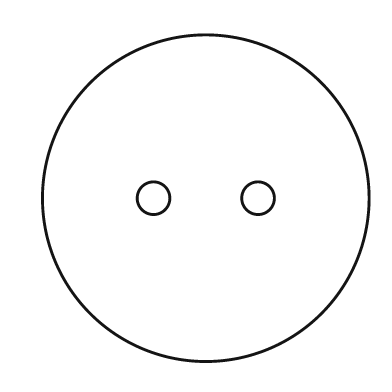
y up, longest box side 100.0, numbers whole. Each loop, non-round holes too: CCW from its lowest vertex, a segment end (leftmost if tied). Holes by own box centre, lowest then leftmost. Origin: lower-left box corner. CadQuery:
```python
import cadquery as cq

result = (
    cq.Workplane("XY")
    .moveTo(50.0, 50.0)
    .circle(50.0)
    .moveTo(34.0, 50.0)
    .circle(5.0)
    .moveTo(66.0, 50.0)
    .circle(5.0)
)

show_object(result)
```